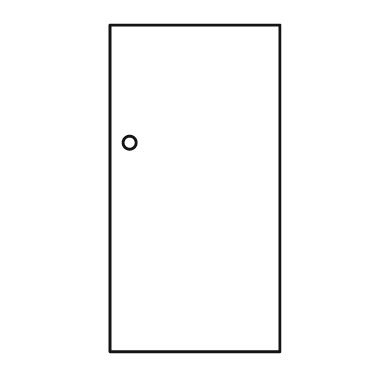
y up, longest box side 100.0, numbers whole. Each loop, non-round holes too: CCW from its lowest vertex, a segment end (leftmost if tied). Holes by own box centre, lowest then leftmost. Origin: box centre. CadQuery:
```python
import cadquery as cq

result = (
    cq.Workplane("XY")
    .moveTo(-26.0, -50.0)
    .lineTo(26.0, -50.0)
    .lineTo(26.0, 50.0)
    .lineTo(-26.0, 50.0)
    .close()
    .moveTo(-20.0, 14.0)
    .circle(2.0)
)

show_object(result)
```